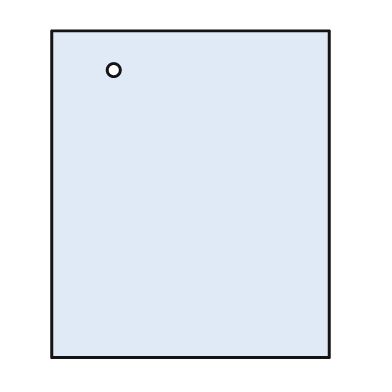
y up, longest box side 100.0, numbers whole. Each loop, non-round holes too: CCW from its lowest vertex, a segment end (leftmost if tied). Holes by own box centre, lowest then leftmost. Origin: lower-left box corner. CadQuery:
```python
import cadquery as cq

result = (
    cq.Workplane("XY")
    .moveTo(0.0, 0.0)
    .lineTo(85.0, 0.0)
    .lineTo(85.0, 100.0)
    .lineTo(0.0, 100.0)
    .close()
    .moveTo(19.0, 88.0)
    .circle(2.0)
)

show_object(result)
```